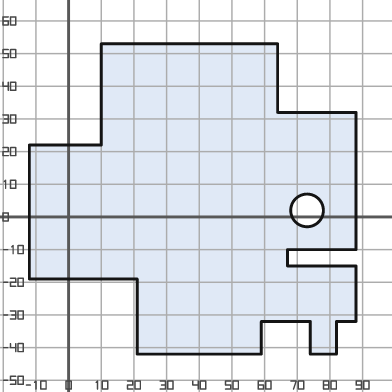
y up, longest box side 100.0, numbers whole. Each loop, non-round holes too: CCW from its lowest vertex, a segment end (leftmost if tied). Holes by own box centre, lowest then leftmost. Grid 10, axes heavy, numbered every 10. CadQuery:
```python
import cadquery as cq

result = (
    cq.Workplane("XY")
    .moveTo(21.0, -42.0)
    .lineTo(59.0, -42.0)
    .lineTo(59.0, -32.0)
    .lineTo(74.0, -32.0)
    .lineTo(74.0, -42.0)
    .lineTo(82.0, -42.0)
    .lineTo(82.0, -32.0)
    .lineTo(88.0, -32.0)
    .lineTo(88.0, -15.0)
    .lineTo(67.0, -15.0)
    .lineTo(67.0, -10.0)
    .lineTo(88.0, -10.0)
    .lineTo(88.0, 32.0)
    .lineTo(64.0, 32.0)
    .lineTo(64.0, 53.0)
    .lineTo(10.0, 53.0)
    .lineTo(10.0, 22.0)
    .lineTo(-12.0, 22.0)
    .lineTo(-12.0, -19.0)
    .lineTo(21.0, -19.0)
    .close()
    .moveTo(73.0, 2.0)
    .circle(5.0)
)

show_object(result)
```